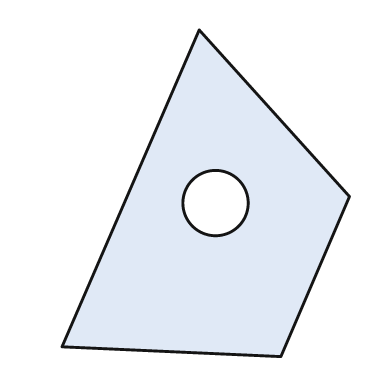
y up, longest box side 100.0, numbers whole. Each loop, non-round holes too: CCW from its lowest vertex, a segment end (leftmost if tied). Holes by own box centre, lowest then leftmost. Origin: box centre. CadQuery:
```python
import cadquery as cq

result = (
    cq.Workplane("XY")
    .moveTo(23.0, -50.0)
    .lineTo(44.0, -1.0)
    .lineTo(-2.0, 50.0)
    .lineTo(-44.0, -47.0)
    .close()
    .moveTo(3.0, -3.0)
    .circle(10.0)
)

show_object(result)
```